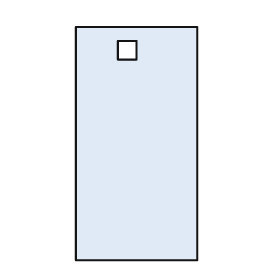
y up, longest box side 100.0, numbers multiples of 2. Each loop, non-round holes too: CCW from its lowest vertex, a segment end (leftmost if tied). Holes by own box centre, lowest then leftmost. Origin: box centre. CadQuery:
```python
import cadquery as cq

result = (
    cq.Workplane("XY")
    .moveTo(-26.0, -50.0)
    .lineTo(26.0, -50.0)
    .lineTo(26.0, 50.0)
    .lineTo(-26.0, 50.0)
    .close()
    .moveTo(-8.0, 36.0)
    .lineTo(0.0, 36.0)
    .lineTo(0.0, 44.0)
    .lineTo(-8.0, 44.0)
    .close()
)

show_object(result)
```